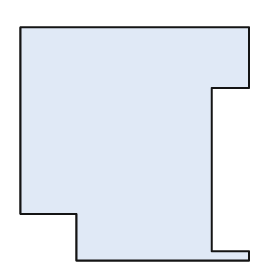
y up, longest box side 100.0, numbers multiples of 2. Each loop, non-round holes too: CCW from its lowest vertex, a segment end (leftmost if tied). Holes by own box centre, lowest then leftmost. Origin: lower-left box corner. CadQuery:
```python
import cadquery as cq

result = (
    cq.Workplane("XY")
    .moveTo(24.0, 0.0)
    .lineTo(98.0, 0.0)
    .lineTo(98.0, 4.0)
    .lineTo(82.0, 4.0)
    .lineTo(82.0, 74.0)
    .lineTo(98.0, 74.0)
    .lineTo(98.0, 100.0)
    .lineTo(0.0, 100.0)
    .lineTo(0.0, 20.0)
    .lineTo(24.0, 20.0)
    .close()
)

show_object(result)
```